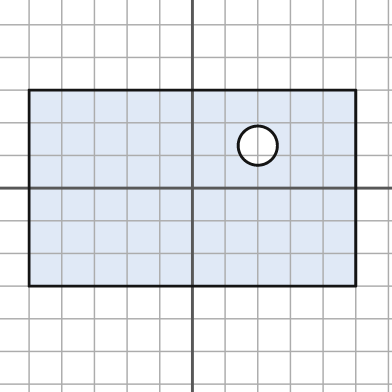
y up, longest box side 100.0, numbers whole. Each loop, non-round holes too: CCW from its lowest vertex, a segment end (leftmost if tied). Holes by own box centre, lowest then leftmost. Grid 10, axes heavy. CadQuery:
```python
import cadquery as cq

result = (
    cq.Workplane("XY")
    .moveTo(-50.0, -30.0)
    .lineTo(50.0, -30.0)
    .lineTo(50.0, 30.0)
    .lineTo(-50.0, 30.0)
    .close()
    .moveTo(20.0, 13.0)
    .circle(6.0)
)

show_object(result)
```